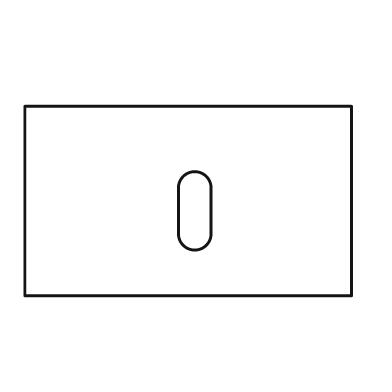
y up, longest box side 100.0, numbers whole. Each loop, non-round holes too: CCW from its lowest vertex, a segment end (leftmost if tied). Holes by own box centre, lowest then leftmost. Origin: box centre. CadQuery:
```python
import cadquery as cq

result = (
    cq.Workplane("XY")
    .moveTo(-50.0, -29.0)
    .lineTo(50.0, -29.0)
    .lineTo(50.0, 29.0)
    .lineTo(-50.0, 29.0)
    .close()
    .moveTo(-3.0, -10.0)
    .threePointArc((2.0, -15.0), (7.0, -10.0))
    .lineTo(7.0, 4.0)
    .threePointArc((2.0, 9.0), (-3.0, 4.0))
    .close()
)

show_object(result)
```